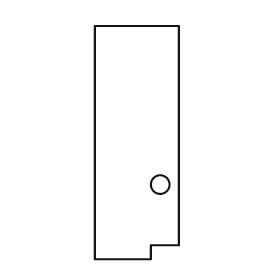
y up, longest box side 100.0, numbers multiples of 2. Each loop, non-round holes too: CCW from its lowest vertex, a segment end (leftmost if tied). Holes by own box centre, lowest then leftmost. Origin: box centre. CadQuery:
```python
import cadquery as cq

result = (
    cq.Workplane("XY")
    .moveTo(-18.0, -50.0)
    .lineTo(6.0, -50.0)
    .lineTo(6.0, -44.0)
    .lineTo(18.0, -44.0)
    .lineTo(18.0, 50.0)
    .lineTo(-18.0, 50.0)
    .close()
    .moveTo(10.0, -18.0)
    .circle(4.0)
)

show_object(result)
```